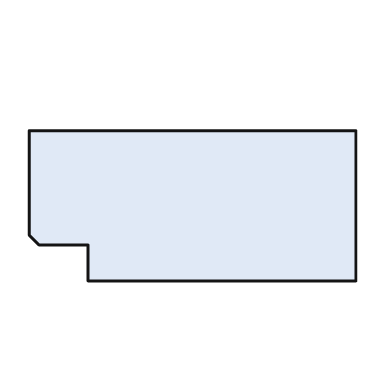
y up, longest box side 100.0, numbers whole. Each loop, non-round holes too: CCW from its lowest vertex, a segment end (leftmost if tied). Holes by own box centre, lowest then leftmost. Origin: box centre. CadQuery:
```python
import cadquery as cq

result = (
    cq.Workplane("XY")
    .moveTo(-32.0, -23.0)
    .lineTo(50.0, -23.0)
    .lineTo(50.0, 23.0)
    .lineTo(-50.0, 23.0)
    .lineTo(-50.0, -9.0)
    .lineTo(-47.0, -12.0)
    .lineTo(-32.0, -12.0)
    .close()
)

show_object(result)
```